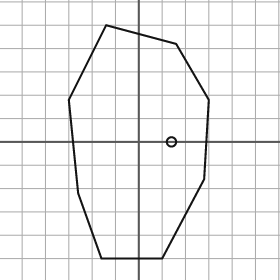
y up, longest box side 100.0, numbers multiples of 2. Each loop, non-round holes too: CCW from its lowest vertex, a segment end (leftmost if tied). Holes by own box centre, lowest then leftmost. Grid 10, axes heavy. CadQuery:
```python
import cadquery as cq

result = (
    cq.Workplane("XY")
    .moveTo(-16.0, -50.0)
    .lineTo(10.0, -50.0)
    .lineTo(28.0, -16.0)
    .lineTo(30.0, 18.0)
    .lineTo(16.0, 42.0)
    .lineTo(-14.0, 50.0)
    .lineTo(-30.0, 18.0)
    .lineTo(-26.0, -22.0)
    .close()
    .moveTo(14.0, 0.0)
    .circle(2.0)
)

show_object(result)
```